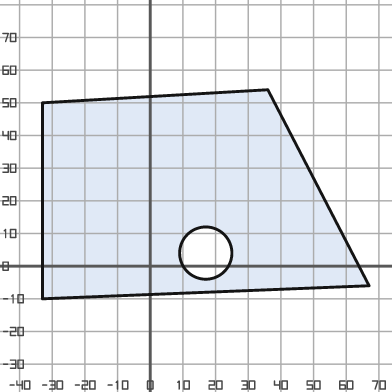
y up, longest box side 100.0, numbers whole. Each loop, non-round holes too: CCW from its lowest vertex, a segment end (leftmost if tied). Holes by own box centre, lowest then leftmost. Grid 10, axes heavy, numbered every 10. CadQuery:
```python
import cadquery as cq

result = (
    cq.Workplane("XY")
    .moveTo(-33.0, -10.0)
    .lineTo(67.0, -6.0)
    .lineTo(36.0, 54.0)
    .lineTo(-33.0, 50.0)
    .close()
    .moveTo(17.0, 4.0)
    .circle(8.0)
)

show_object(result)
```